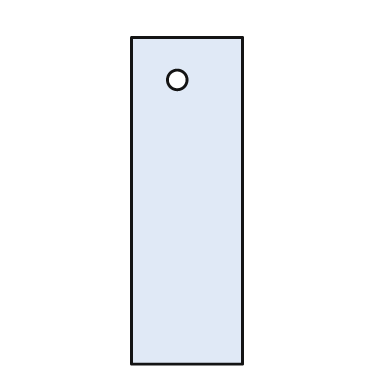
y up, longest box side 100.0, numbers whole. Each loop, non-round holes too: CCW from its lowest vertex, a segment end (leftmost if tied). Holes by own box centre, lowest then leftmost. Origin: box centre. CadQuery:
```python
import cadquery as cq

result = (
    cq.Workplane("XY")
    .moveTo(-17.0, -50.0)
    .lineTo(17.0, -50.0)
    .lineTo(17.0, 50.0)
    .lineTo(-17.0, 50.0)
    .close()
    .moveTo(-3.0, 37.0)
    .circle(3.0)
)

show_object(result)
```